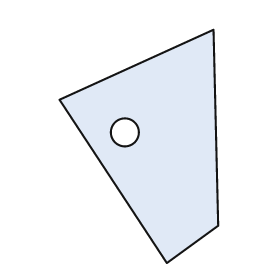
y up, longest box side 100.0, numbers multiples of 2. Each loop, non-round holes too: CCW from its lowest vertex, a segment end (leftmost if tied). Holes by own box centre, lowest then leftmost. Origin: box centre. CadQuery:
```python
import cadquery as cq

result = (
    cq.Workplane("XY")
    .moveTo(12.0, -50.0)
    .lineTo(34.0, -34.0)
    .lineTo(32.0, 50.0)
    .lineTo(-34.0, 20.0)
    .close()
    .moveTo(-6.0, 6.0)
    .circle(6.0)
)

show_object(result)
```